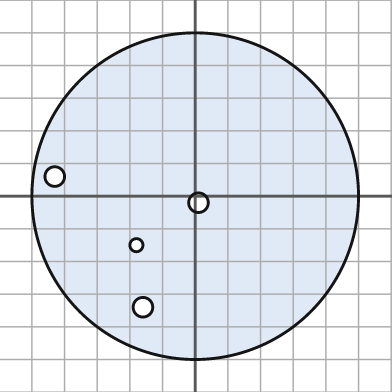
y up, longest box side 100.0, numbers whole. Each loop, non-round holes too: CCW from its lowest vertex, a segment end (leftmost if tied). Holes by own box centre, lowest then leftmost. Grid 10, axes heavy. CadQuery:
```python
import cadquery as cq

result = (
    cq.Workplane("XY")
    .moveTo(0.0, 0.0)
    .circle(50.0)
    .moveTo(-16.0, -34.0)
    .circle(3.0)
    .moveTo(-18.0, -15.0)
    .circle(2.0)
    .moveTo(1.0, -2.0)
    .circle(3.0)
    .moveTo(-43.0, 6.0)
    .circle(3.0)
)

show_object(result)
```